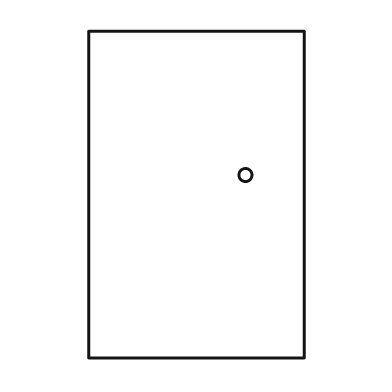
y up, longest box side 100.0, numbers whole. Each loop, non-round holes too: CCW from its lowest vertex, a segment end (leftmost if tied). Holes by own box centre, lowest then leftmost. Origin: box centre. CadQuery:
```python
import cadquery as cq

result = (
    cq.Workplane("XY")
    .moveTo(-33.0, -50.0)
    .lineTo(33.0, -50.0)
    .lineTo(33.0, 50.0)
    .lineTo(-33.0, 50.0)
    .close()
    .moveTo(15.0, 6.0)
    .circle(2.0)
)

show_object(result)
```